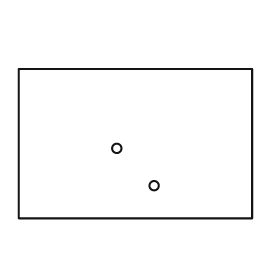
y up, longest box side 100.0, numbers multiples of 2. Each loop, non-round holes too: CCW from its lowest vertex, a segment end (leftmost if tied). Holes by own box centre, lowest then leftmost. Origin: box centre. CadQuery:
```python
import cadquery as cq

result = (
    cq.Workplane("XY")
    .moveTo(-50.0, -32.0)
    .lineTo(50.0, -32.0)
    .lineTo(50.0, 32.0)
    .lineTo(-50.0, 32.0)
    .close()
    .moveTo(8.0, -18.0)
    .circle(2.0)
    .moveTo(-8.0, -2.0)
    .circle(2.0)
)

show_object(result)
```